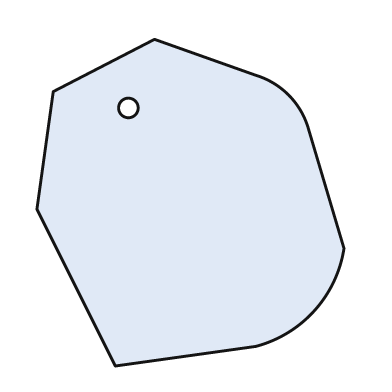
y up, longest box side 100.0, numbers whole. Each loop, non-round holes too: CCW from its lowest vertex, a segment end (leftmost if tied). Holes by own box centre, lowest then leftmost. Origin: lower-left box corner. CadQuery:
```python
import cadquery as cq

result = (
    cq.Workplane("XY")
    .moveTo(24.0, 0.0)
    .lineTo(67.0, 6.0)
    .threePointArc((85.0, 17.0), (94.0, 36.0))
    .lineTo(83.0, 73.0)
    .threePointArc((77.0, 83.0), (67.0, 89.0))
    .lineTo(36.0, 100.0)
    .lineTo(5.0, 84.0)
    .lineTo(0.0, 48.0)
    .close()
    .moveTo(28.0, 79.0)
    .circle(3.0)
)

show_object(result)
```